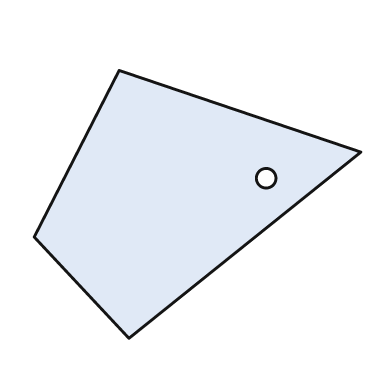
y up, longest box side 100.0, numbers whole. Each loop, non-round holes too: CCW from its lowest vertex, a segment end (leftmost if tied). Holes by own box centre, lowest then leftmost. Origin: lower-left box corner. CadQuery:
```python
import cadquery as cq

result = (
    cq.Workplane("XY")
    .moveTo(29.0, 0.0)
    .lineTo(100.0, 57.0)
    .lineTo(26.0, 82.0)
    .lineTo(0.0, 31.0)
    .close()
    .moveTo(71.0, 49.0)
    .circle(3.0)
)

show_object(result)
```